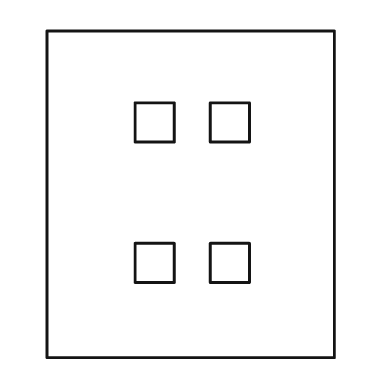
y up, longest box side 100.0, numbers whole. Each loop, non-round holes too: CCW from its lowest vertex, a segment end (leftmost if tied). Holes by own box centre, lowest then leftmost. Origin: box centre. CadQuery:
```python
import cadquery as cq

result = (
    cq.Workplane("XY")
    .moveTo(-44.0, -50.0)
    .lineTo(44.0, -50.0)
    .lineTo(44.0, 50.0)
    .lineTo(-44.0, 50.0)
    .close()
    .moveTo(-17.0, -27.0)
    .lineTo(-5.0, -27.0)
    .lineTo(-5.0, -15.0)
    .lineTo(-17.0, -15.0)
    .close()
    .moveTo(6.0, -27.0)
    .lineTo(18.0, -27.0)
    .lineTo(18.0, -15.0)
    .lineTo(6.0, -15.0)
    .close()
    .moveTo(-17.0, 16.0)
    .lineTo(-5.0, 16.0)
    .lineTo(-5.0, 28.0)
    .lineTo(-17.0, 28.0)
    .close()
    .moveTo(6.0, 16.0)
    .lineTo(18.0, 16.0)
    .lineTo(18.0, 28.0)
    .lineTo(6.0, 28.0)
    .close()
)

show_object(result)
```